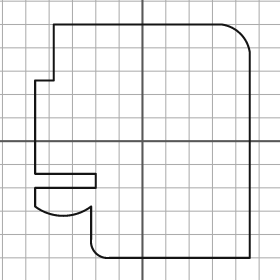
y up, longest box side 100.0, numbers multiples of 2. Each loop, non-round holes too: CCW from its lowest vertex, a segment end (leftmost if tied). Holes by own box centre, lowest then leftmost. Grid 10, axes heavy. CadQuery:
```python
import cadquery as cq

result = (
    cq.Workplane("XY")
    .moveTo(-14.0, -50.0)
    .lineTo(46.0, -50.0)
    .lineTo(46.0, 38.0)
    .threePointArc((42.0, 46.0), (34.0, 50.0))
    .lineTo(-38.0, 50.0)
    .lineTo(-38.0, 26.0)
    .lineTo(-46.0, 26.0)
    .lineTo(-46.0, -14.0)
    .lineTo(-20.0, -14.0)
    .lineTo(-20.0, -20.0)
    .lineTo(-46.0, -20.0)
    .lineTo(-46.0, -28.0)
    .threePointArc((-34.0, -32.0), (-22.0, -28.0))
    .lineTo(-22.0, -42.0)
    .threePointArc((-20.0, -48.0), (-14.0, -50.0))
    .close()
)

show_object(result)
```